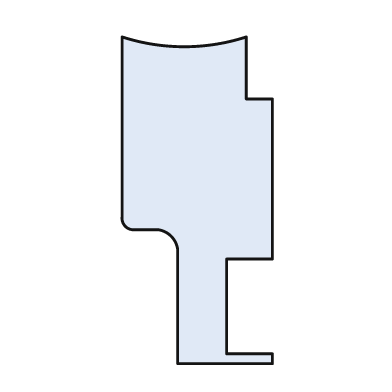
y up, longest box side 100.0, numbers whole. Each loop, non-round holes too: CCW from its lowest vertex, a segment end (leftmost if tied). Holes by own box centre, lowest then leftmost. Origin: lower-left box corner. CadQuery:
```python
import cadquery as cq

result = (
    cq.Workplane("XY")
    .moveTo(17.0, 0.0)
    .lineTo(46.0, 0.0)
    .lineTo(46.0, 3.0)
    .lineTo(32.0, 3.0)
    .lineTo(32.0, 32.0)
    .lineTo(46.0, 32.0)
    .lineTo(46.0, 81.0)
    .lineTo(38.0, 81.0)
    .lineTo(38.0, 100.0)
    .threePointArc((19.0, 97.0), (0.0, 100.0))
    .lineTo(0.0, 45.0)
    .threePointArc((1.0, 42.0), (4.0, 41.0))
    .lineTo(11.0, 41.0)
    .threePointArc((15.0, 39.0), (17.0, 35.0))
    .close()
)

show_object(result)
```